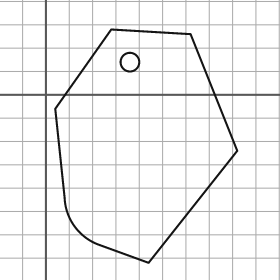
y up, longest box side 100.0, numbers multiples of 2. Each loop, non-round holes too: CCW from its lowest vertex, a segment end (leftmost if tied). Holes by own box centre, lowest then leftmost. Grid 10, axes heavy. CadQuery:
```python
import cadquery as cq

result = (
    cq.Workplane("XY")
    .moveTo(44.0, -72.0)
    .lineTo(82.0, -24.0)
    .lineTo(62.0, 26.0)
    .lineTo(28.0, 28.0)
    .lineTo(4.0, -6.0)
    .lineTo(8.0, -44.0)
    .threePointArc((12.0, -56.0), (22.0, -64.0))
    .close()
    .moveTo(36.0, 14.0)
    .circle(4.0)
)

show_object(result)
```